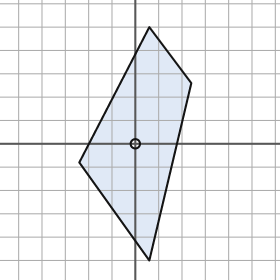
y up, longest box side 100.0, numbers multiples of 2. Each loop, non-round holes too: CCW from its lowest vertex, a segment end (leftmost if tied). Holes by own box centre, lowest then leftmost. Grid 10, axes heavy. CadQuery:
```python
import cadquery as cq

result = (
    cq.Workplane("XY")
    .moveTo(6.0, -50.0)
    .lineTo(24.0, 26.0)
    .lineTo(6.0, 50.0)
    .lineTo(-24.0, -8.0)
    .close()
    .moveTo(0.0, 0.0)
    .circle(2.0)
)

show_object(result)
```